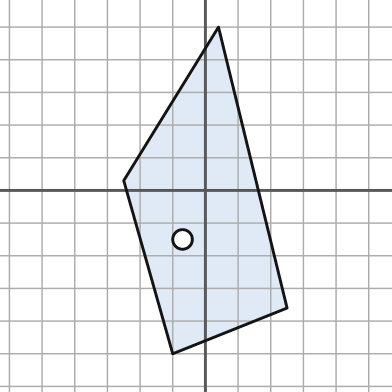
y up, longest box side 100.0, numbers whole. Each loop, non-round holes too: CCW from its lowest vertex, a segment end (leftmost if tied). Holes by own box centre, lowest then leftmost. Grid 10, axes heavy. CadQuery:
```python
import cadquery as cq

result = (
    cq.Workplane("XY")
    .moveTo(-10.0, -50.0)
    .lineTo(25.0, -36.0)
    .lineTo(4.0, 50.0)
    .lineTo(-25.0, 3.0)
    .close()
    .moveTo(-7.0, -15.0)
    .circle(3.0)
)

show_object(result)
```